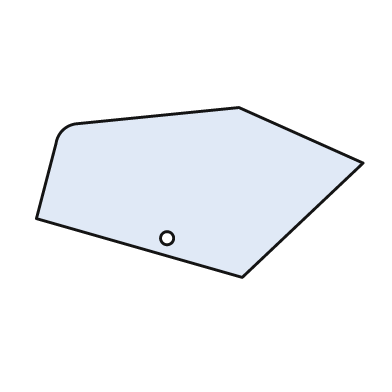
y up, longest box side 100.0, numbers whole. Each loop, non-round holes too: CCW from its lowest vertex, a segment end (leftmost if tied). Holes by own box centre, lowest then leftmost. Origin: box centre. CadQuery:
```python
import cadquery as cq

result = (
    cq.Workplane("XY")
    .moveTo(13.0, -26.0)
    .lineTo(50.0, 9.0)
    .lineTo(12.0, 26.0)
    .lineTo(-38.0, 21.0)
    .threePointArc((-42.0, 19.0), (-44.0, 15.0))
    .lineTo(-50.0, -8.0)
    .close()
    .moveTo(-10.0, -14.0)
    .circle(2.0)
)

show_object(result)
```